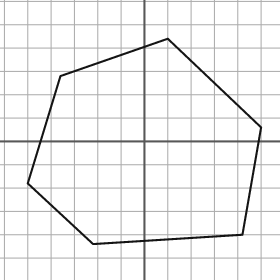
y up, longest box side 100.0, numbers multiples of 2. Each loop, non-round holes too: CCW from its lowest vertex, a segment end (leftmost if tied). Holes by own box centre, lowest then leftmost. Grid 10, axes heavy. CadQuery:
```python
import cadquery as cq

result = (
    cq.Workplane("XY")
    .moveTo(-22.0, -44.0)
    .lineTo(42.0, -40.0)
    .lineTo(50.0, 6.0)
    .lineTo(10.0, 44.0)
    .lineTo(-36.0, 28.0)
    .lineTo(-50.0, -18.0)
    .close()
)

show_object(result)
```